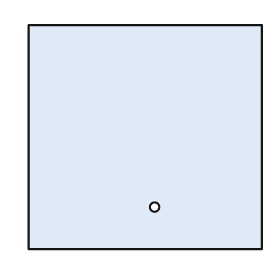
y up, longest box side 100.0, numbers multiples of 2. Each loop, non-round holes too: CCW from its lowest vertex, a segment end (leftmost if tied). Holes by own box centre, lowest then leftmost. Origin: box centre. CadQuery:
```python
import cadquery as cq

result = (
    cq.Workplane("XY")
    .moveTo(-50.0, -48.0)
    .lineTo(50.0, -48.0)
    .lineTo(50.0, 48.0)
    .lineTo(-50.0, 48.0)
    .close()
    .moveTo(4.0, -30.0)
    .circle(2.0)
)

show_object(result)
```